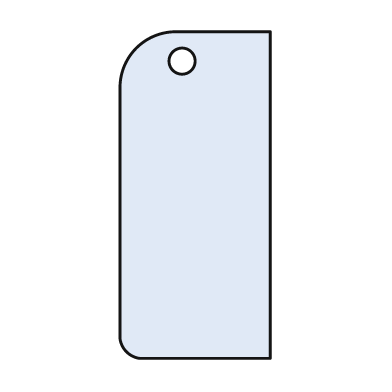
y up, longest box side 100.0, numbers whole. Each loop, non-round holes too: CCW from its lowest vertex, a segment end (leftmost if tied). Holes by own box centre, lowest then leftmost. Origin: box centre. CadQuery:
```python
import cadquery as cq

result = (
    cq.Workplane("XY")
    .moveTo(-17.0, -50.0)
    .lineTo(23.0, -50.0)
    .lineTo(23.0, 50.0)
    .lineTo(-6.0, 50.0)
    .threePointArc((-18.0, 45.0), (-23.0, 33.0))
    .lineTo(-23.0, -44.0)
    .threePointArc((-21.0, -48.0), (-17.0, -50.0))
    .close()
    .moveTo(-4.0, 41.0)
    .circle(4.0)
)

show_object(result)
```